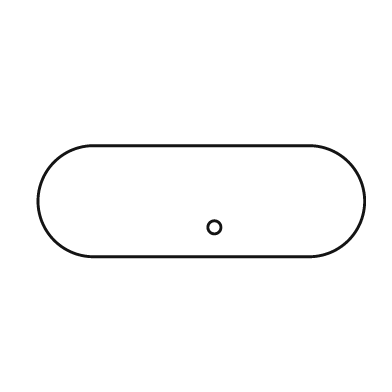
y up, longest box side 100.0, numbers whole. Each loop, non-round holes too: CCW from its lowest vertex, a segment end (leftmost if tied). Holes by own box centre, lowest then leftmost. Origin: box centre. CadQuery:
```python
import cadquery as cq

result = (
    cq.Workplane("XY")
    .moveTo(-33.0, -17.0)
    .lineTo(33.0, -17.0)
    .threePointArc((50.0, 0.0), (33.0, 17.0))
    .lineTo(-33.0, 17.0)
    .threePointArc((-50.0, 0.0), (-33.0, -17.0))
    .close()
    .moveTo(4.0, -8.0)
    .circle(2.0)
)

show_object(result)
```